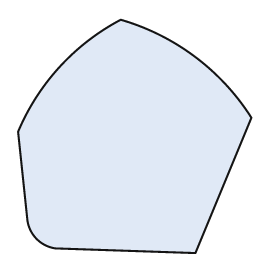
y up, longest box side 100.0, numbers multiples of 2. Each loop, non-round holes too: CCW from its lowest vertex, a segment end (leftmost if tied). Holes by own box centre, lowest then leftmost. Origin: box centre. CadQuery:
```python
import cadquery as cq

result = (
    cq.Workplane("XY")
    .moveTo(26.0, -50.0)
    .lineTo(50.0, 8.0)
    .threePointArc((26.0, 34.0), (-6.0, 50.0))
    .threePointArc((-32.0, 30.0), (-50.0, 2.0))
    .lineTo(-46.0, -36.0)
    .threePointArc((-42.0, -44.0), (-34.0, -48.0))
    .close()
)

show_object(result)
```